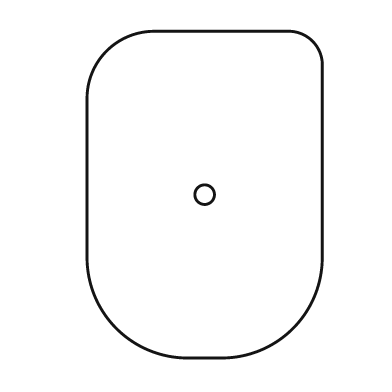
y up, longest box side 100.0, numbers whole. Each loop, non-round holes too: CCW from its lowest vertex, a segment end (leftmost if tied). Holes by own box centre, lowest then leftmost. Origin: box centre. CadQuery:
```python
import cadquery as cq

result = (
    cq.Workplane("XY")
    .moveTo(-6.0, -50.0)
    .lineTo(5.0, -50.0)
    .threePointArc((27.0, -41.0), (36.0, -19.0))
    .lineTo(36.0, 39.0)
    .threePointArc((33.0, 47.0), (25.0, 50.0))
    .lineTo(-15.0, 50.0)
    .threePointArc((-30.0, 44.0), (-36.0, 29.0))
    .lineTo(-36.0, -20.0)
    .threePointArc((-27.0, -41.0), (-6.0, -50.0))
    .close()
    .moveTo(0.0, 0.0)
    .circle(3.0)
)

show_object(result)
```